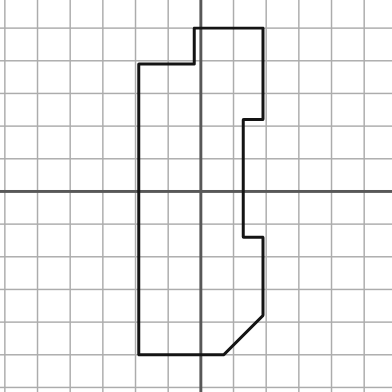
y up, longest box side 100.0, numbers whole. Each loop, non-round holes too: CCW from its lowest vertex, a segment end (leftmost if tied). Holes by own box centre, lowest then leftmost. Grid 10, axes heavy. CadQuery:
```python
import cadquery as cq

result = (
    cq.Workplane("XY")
    .moveTo(-19.0, -50.0)
    .lineTo(7.0, -50.0)
    .lineTo(19.0, -38.0)
    .lineTo(19.0, -14.0)
    .lineTo(13.0, -14.0)
    .lineTo(13.0, 22.0)
    .lineTo(19.0, 22.0)
    .lineTo(19.0, 50.0)
    .lineTo(-2.0, 50.0)
    .lineTo(-2.0, 39.0)
    .lineTo(-19.0, 39.0)
    .close()
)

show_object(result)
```